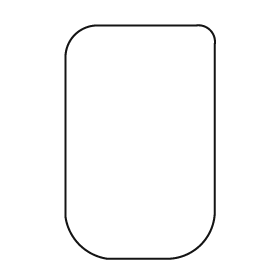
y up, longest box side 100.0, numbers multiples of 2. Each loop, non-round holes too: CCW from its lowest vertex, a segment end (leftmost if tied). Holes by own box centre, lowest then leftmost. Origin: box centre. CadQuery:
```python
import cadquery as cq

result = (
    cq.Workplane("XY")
    .moveTo(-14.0, -50.0)
    .lineTo(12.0, -50.0)
    .threePointArc((26.0, -44.0), (32.0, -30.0))
    .lineTo(32.0, 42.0)
    .threePointArc((30.0, 48.0), (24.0, 50.0))
    .lineTo(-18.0, 50.0)
    .threePointArc((-28.0, 46.0), (-32.0, 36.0))
    .lineTo(-32.0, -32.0)
    .threePointArc((-26.0, -44.0), (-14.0, -50.0))
    .close()
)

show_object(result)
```